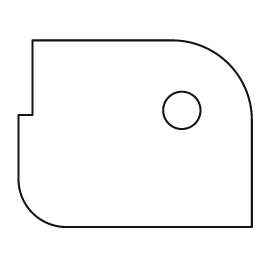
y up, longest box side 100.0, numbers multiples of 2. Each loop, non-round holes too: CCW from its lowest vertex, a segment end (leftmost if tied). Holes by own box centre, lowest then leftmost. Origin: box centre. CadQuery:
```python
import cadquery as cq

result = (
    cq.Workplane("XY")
    .moveTo(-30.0, -40.0)
    .lineTo(50.0, -40.0)
    .lineTo(50.0, 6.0)
    .threePointArc((40.0, 30.0), (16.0, 40.0))
    .lineTo(-44.0, 40.0)
    .lineTo(-44.0, 8.0)
    .lineTo(-50.0, 8.0)
    .lineTo(-50.0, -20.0)
    .threePointArc((-44.0, -34.0), (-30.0, -40.0))
    .close()
    .moveTo(20.0, 10.0)
    .circle(8.0)
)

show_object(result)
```